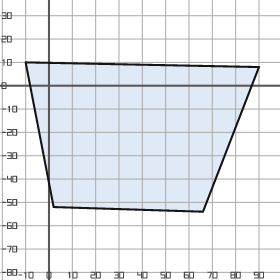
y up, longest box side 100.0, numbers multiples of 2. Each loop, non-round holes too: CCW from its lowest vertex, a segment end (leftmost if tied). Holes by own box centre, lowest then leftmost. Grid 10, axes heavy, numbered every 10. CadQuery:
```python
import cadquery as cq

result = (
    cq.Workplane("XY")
    .moveTo(66.0, -54.0)
    .lineTo(90.0, 8.0)
    .lineTo(-10.0, 10.0)
    .lineTo(2.0, -52.0)
    .close()
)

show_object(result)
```